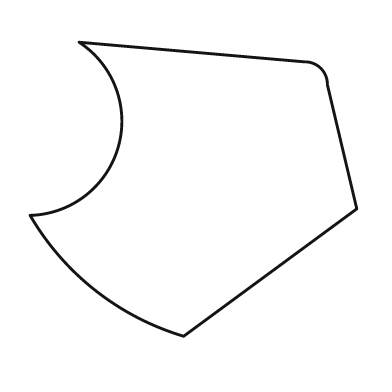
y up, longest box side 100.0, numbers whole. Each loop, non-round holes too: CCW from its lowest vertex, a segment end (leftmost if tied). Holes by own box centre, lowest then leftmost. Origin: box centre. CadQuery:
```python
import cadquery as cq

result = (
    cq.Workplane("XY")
    .moveTo(-3.0, -45.0)
    .lineTo(50.0, -6.0)
    .lineTo(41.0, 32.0)
    .threePointArc((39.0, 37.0), (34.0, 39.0))
    .lineTo(-35.0, 45.0)
    .threePointArc((-23.0, 13.0), (-50.0, -8.0))
    .threePointArc((-30.0, -31.0), (-3.0, -45.0))
    .close()
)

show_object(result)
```